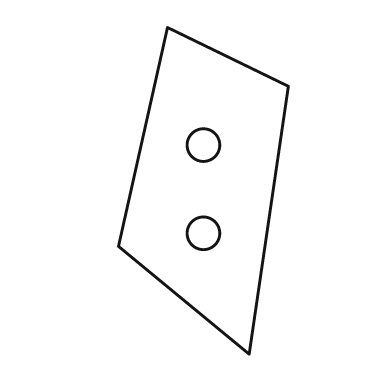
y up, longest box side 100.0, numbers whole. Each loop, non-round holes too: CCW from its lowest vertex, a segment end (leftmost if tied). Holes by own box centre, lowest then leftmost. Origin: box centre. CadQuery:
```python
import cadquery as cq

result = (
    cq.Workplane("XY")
    .moveTo(14.0, -50.0)
    .lineTo(26.0, 32.0)
    .lineTo(-11.0, 50.0)
    .lineTo(-26.0, -17.0)
    .close()
    .moveTo(0.0, -13.0)
    .circle(5.0)
    .moveTo(0.0, 14.0)
    .circle(5.0)
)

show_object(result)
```